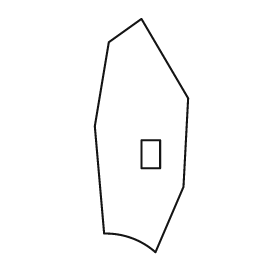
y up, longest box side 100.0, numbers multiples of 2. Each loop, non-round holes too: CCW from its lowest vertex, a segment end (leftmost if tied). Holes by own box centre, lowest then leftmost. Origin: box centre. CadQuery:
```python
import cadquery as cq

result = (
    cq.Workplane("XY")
    .moveTo(6.0, -50.0)
    .lineTo(18.0, -22.0)
    .lineTo(20.0, 16.0)
    .lineTo(0.0, 50.0)
    .lineTo(-14.0, 40.0)
    .lineTo(-20.0, 4.0)
    .lineTo(-16.0, -42.0)
    .threePointArc((-4.0, -44.0), (6.0, -50.0))
    .close()
    .moveTo(0.0, -14.0)
    .lineTo(8.0, -14.0)
    .lineTo(8.0, -2.0)
    .lineTo(0.0, -2.0)
    .close()
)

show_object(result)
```